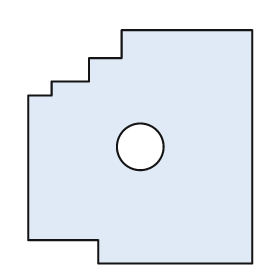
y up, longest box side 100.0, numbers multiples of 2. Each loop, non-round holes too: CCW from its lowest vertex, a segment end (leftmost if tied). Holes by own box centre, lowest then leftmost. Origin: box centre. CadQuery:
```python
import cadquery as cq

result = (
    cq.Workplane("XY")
    .moveTo(-18.0, -50.0)
    .lineTo(48.0, -50.0)
    .lineTo(48.0, 50.0)
    .lineTo(-8.0, 50.0)
    .lineTo(-8.0, 38.0)
    .lineTo(-22.0, 38.0)
    .lineTo(-22.0, 28.0)
    .lineTo(-38.0, 28.0)
    .lineTo(-38.0, 22.0)
    .lineTo(-48.0, 22.0)
    .lineTo(-48.0, -40.0)
    .lineTo(-18.0, -40.0)
    .close()
    .moveTo(0.0, 0.0)
    .circle(10.0)
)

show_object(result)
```